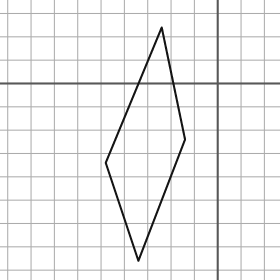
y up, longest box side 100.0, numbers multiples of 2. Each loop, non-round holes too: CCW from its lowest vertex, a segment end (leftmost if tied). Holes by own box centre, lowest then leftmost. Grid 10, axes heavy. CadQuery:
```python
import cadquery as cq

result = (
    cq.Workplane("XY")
    .moveTo(-34.0, -76.0)
    .lineTo(-14.0, -24.0)
    .lineTo(-24.0, 24.0)
    .lineTo(-48.0, -34.0)
    .close()
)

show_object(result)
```